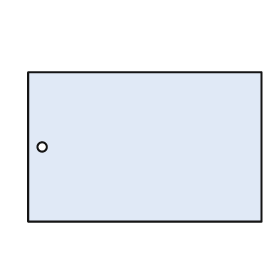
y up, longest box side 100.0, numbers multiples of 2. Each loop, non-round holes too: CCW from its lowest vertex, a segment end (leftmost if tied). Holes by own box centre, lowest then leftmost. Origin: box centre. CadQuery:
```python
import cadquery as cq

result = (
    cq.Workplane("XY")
    .moveTo(-50.0, -32.0)
    .lineTo(50.0, -32.0)
    .lineTo(50.0, 32.0)
    .lineTo(-50.0, 32.0)
    .close()
    .moveTo(-44.0, 0.0)
    .circle(2.0)
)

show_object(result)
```